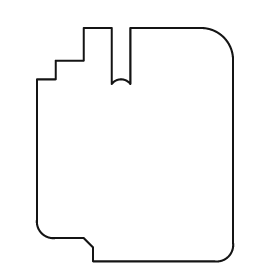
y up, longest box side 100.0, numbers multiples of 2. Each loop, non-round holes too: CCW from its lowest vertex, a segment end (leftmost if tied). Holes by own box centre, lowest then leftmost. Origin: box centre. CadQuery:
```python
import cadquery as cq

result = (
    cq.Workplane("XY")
    .moveTo(-18.0, -50.0)
    .lineTo(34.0, -50.0)
    .threePointArc((40.0, -48.0), (42.0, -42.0))
    .lineTo(42.0, 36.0)
    .threePointArc((38.0, 46.0), (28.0, 50.0))
    .lineTo(-2.0, 50.0)
    .lineTo(-2.0, 26.0)
    .threePointArc((-6.0, 28.0), (-10.0, 26.0))
    .lineTo(-10.0, 50.0)
    .lineTo(-22.0, 50.0)
    .lineTo(-22.0, 36.0)
    .lineTo(-34.0, 36.0)
    .lineTo(-34.0, 28.0)
    .lineTo(-42.0, 28.0)
    .lineTo(-42.0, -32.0)
    .threePointArc((-40.0, -38.0), (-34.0, -40.0))
    .lineTo(-22.0, -40.0)
    .lineTo(-18.0, -44.0)
    .close()
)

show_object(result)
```